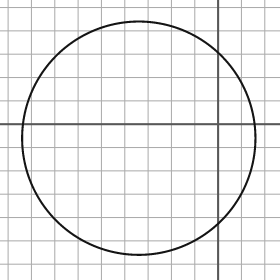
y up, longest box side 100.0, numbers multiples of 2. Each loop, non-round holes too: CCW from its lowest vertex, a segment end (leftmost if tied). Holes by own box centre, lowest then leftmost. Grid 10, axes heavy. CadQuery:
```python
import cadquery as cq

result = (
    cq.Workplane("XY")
    .moveTo(-34.0, -6.0)
    .circle(50.0)
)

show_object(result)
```